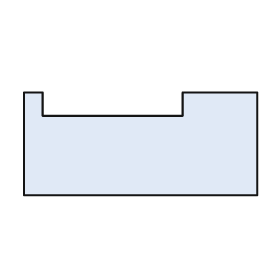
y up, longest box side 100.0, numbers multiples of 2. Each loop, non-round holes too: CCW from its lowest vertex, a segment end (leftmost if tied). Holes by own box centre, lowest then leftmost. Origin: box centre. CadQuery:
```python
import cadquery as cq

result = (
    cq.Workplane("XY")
    .moveTo(-50.0, -22.0)
    .lineTo(50.0, -22.0)
    .lineTo(50.0, 22.0)
    .lineTo(18.0, 22.0)
    .lineTo(18.0, 12.0)
    .lineTo(-42.0, 12.0)
    .lineTo(-42.0, 22.0)
    .lineTo(-50.0, 22.0)
    .close()
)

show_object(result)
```